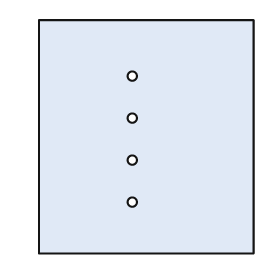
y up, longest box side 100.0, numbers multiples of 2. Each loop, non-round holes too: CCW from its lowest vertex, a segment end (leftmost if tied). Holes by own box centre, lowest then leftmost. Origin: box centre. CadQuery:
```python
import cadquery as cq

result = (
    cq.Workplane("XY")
    .moveTo(-46.0, -50.0)
    .lineTo(46.0, -50.0)
    .lineTo(46.0, 50.0)
    .lineTo(-46.0, 50.0)
    .close()
    .moveTo(-6.0, -28.0)
    .circle(2.0)
    .moveTo(-6.0, -10.0)
    .circle(2.0)
    .moveTo(-6.0, 8.0)
    .circle(2.0)
    .moveTo(-6.0, 26.0)
    .circle(2.0)
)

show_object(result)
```